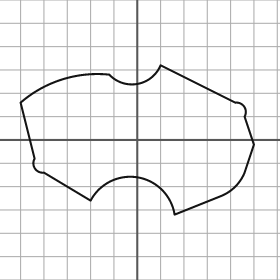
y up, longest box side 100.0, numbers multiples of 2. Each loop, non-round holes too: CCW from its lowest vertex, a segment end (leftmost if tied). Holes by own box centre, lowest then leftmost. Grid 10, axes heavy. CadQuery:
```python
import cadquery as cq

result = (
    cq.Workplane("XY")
    .moveTo(16.0, -32.0)
    .lineTo(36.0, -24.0)
    .threePointArc((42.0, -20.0), (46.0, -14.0))
    .lineTo(50.0, -2.0)
    .lineTo(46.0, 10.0)
    .threePointArc((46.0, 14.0), (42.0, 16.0))
    .lineTo(10.0, 32.0)
    .threePointArc((0.0, 24.0), (-12.0, 28.0))
    .threePointArc((-32.0, 26.0), (-50.0, 16.0))
    .lineTo(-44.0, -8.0)
    .threePointArc((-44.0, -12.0), (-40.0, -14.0))
    .lineTo(-20.0, -26.0)
    .threePointArc((0.0, -16.0), (16.0, -32.0))
    .close()
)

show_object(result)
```